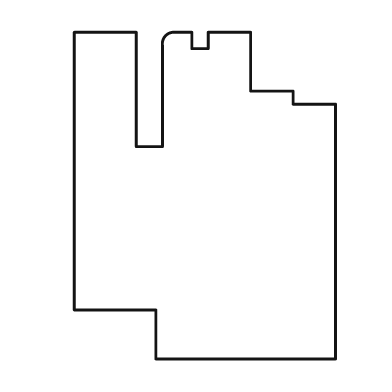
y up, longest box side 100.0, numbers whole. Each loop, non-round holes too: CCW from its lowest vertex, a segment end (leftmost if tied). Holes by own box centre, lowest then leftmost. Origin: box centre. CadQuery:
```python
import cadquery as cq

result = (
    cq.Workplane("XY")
    .moveTo(-15.0, -50.0)
    .lineTo(40.0, -50.0)
    .lineTo(40.0, 28.0)
    .lineTo(27.0, 28.0)
    .lineTo(27.0, 32.0)
    .lineTo(14.0, 32.0)
    .lineTo(14.0, 50.0)
    .lineTo(1.0, 50.0)
    .lineTo(1.0, 45.0)
    .lineTo(-4.0, 45.0)
    .lineTo(-4.0, 50.0)
    .lineTo(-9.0, 50.0)
    .threePointArc((-12.0, 49.0), (-13.0, 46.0))
    .lineTo(-13.0, 15.0)
    .lineTo(-21.0, 15.0)
    .lineTo(-21.0, 50.0)
    .lineTo(-40.0, 50.0)
    .lineTo(-40.0, -35.0)
    .lineTo(-15.0, -35.0)
    .close()
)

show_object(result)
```